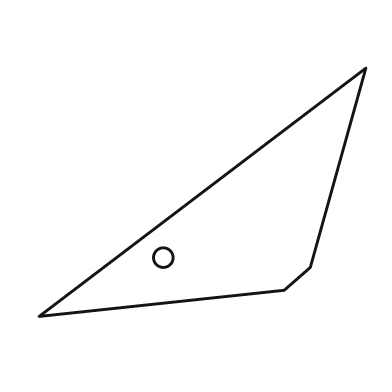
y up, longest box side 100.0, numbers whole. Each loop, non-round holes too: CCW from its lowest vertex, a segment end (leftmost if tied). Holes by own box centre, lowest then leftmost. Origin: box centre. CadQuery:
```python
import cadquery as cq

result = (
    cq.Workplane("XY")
    .moveTo(-50.0, -38.0)
    .lineTo(25.0, -30.0)
    .lineTo(33.0, -23.0)
    .lineTo(50.0, 38.0)
    .close()
    .moveTo(-12.0, -20.0)
    .circle(3.0)
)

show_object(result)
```